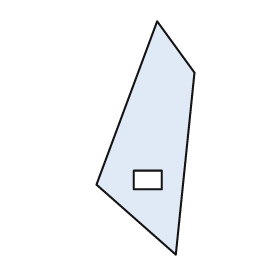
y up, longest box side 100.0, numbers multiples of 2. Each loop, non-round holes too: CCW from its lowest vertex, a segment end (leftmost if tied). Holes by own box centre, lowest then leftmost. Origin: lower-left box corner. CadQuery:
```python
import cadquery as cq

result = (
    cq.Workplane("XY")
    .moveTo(34.0, 0.0)
    .lineTo(42.0, 78.0)
    .lineTo(26.0, 100.0)
    .lineTo(0.0, 30.0)
    .close()
    .moveTo(16.0, 28.0)
    .lineTo(28.0, 28.0)
    .lineTo(28.0, 36.0)
    .lineTo(16.0, 36.0)
    .close()
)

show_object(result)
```